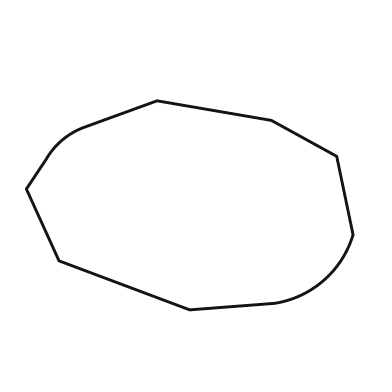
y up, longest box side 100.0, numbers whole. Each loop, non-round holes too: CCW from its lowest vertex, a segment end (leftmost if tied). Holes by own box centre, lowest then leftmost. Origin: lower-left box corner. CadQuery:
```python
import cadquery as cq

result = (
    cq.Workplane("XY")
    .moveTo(50.0, 0.0)
    .lineTo(76.0, 2.0)
    .threePointArc((91.0, 9.0), (100.0, 23.0))
    .lineTo(95.0, 47.0)
    .lineTo(75.0, 58.0)
    .lineTo(40.0, 64.0)
    .lineTo(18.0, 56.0)
    .threePointArc((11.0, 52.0), (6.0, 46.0))
    .lineTo(0.0, 37.0)
    .lineTo(10.0, 15.0)
    .close()
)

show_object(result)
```